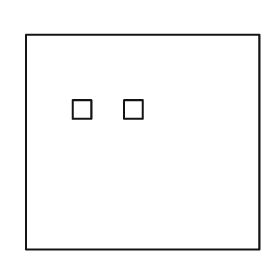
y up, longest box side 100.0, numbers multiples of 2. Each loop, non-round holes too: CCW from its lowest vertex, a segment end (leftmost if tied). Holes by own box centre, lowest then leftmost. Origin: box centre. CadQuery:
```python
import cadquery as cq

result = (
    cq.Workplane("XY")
    .moveTo(-50.0, -46.0)
    .lineTo(50.0, -46.0)
    .lineTo(50.0, 46.0)
    .lineTo(-50.0, 46.0)
    .close()
    .moveTo(-30.0, 10.0)
    .lineTo(-22.0, 10.0)
    .lineTo(-22.0, 18.0)
    .lineTo(-30.0, 18.0)
    .close()
    .moveTo(-8.0, 10.0)
    .lineTo(0.0, 10.0)
    .lineTo(0.0, 18.0)
    .lineTo(-8.0, 18.0)
    .close()
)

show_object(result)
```